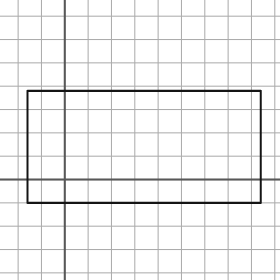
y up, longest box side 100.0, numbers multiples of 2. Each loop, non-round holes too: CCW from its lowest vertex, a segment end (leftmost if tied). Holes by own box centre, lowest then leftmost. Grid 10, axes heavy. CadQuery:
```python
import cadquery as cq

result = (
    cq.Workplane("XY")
    .moveTo(-16.0, -10.0)
    .lineTo(84.0, -10.0)
    .lineTo(84.0, 38.0)
    .lineTo(-16.0, 38.0)
    .close()
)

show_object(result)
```